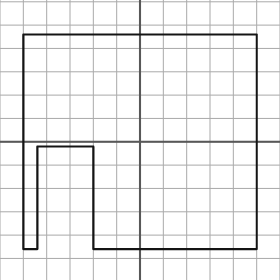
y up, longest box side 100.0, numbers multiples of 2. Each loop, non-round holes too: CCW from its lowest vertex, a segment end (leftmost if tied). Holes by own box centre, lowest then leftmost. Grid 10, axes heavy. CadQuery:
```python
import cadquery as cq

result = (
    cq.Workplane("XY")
    .moveTo(-50.0, -46.0)
    .lineTo(-44.0, -46.0)
    .lineTo(-44.0, -2.0)
    .lineTo(-20.0, -2.0)
    .lineTo(-20.0, -46.0)
    .lineTo(50.0, -46.0)
    .lineTo(50.0, 46.0)
    .lineTo(-50.0, 46.0)
    .close()
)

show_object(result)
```